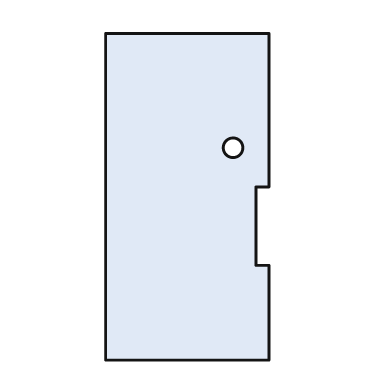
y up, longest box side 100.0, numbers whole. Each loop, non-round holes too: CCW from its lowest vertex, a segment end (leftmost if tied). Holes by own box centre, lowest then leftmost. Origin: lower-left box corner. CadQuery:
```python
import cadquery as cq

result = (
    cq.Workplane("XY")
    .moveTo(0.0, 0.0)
    .lineTo(50.0, 0.0)
    .lineTo(50.0, 29.0)
    .lineTo(46.0, 29.0)
    .lineTo(46.0, 53.0)
    .lineTo(50.0, 53.0)
    .lineTo(50.0, 100.0)
    .lineTo(0.0, 100.0)
    .close()
    .moveTo(39.0, 65.0)
    .circle(3.0)
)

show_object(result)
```